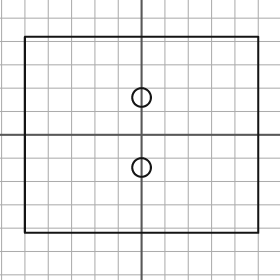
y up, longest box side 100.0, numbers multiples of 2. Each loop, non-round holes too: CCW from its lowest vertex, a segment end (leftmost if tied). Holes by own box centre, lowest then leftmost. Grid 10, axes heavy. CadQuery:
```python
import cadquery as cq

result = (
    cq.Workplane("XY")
    .moveTo(-50.0, -42.0)
    .lineTo(50.0, -42.0)
    .lineTo(50.0, 42.0)
    .lineTo(-50.0, 42.0)
    .close()
    .moveTo(0.0, -14.0)
    .circle(4.0)
    .moveTo(0.0, 16.0)
    .circle(4.0)
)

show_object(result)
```